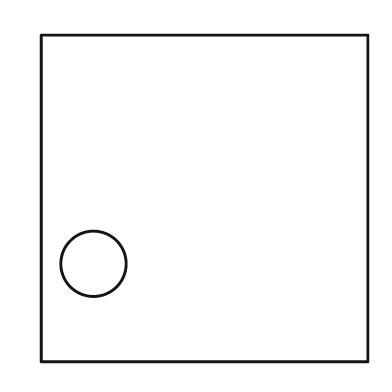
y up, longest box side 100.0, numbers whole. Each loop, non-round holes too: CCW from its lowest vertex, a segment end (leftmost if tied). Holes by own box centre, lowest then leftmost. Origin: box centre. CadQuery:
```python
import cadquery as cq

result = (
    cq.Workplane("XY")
    .moveTo(-50.0, -50.0)
    .lineTo(50.0, -50.0)
    .lineTo(50.0, 50.0)
    .lineTo(-50.0, 50.0)
    .close()
    .moveTo(-34.0, -20.0)
    .circle(10.0)
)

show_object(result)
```